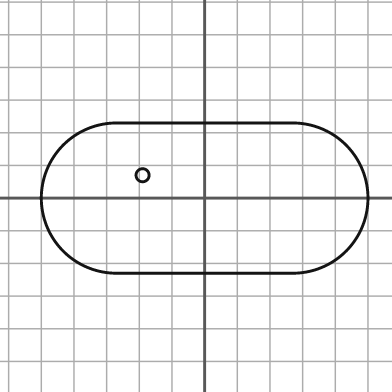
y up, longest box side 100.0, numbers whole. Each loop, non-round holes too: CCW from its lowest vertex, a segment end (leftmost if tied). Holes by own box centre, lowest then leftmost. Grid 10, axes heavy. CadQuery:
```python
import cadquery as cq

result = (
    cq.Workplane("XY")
    .moveTo(-27.0, -23.0)
    .lineTo(27.0, -23.0)
    .threePointArc((50.0, 0.0), (27.0, 23.0))
    .lineTo(-27.0, 23.0)
    .threePointArc((-50.0, 0.0), (-27.0, -23.0))
    .close()
    .moveTo(-19.0, 7.0)
    .circle(2.0)
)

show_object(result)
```